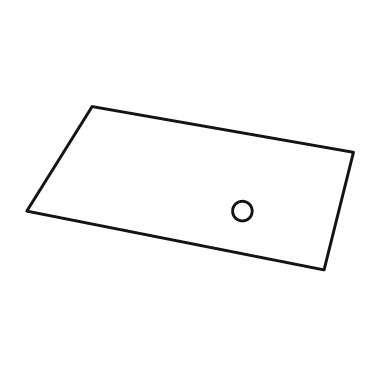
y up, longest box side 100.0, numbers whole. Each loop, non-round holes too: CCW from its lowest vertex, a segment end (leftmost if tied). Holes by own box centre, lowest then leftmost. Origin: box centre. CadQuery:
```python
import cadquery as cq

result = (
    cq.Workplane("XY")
    .moveTo(41.0, -25.0)
    .lineTo(50.0, 11.0)
    .lineTo(-30.0, 25.0)
    .lineTo(-50.0, -7.0)
    .close()
    .moveTo(16.0, -7.0)
    .circle(3.0)
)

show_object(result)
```